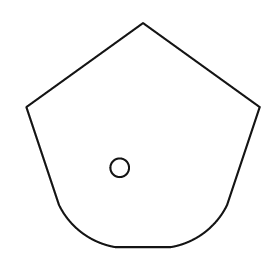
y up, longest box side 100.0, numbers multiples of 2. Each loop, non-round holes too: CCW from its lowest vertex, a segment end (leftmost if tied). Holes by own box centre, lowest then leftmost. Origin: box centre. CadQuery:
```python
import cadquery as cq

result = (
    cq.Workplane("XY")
    .moveTo(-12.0, -48.0)
    .lineTo(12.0, -48.0)
    .threePointArc((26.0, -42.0), (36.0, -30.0))
    .lineTo(50.0, 12.0)
    .lineTo(0.0, 48.0)
    .lineTo(-50.0, 12.0)
    .lineTo(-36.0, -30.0)
    .threePointArc((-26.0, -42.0), (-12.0, -48.0))
    .close()
    .moveTo(-10.0, -14.0)
    .circle(4.0)
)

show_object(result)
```